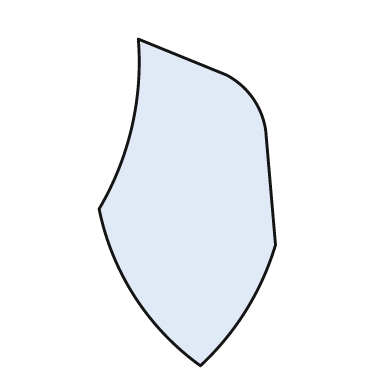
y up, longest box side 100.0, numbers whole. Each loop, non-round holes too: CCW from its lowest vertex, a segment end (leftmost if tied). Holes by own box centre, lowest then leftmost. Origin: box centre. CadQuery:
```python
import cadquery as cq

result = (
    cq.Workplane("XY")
    .moveTo(4.0, -50.0)
    .threePointArc((18.0, -33.0), (27.0, -13.0))
    .lineTo(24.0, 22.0)
    .threePointArc((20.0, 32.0), (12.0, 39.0))
    .lineTo(-15.0, 50.0)
    .threePointArc((-17.0, 23.0), (-27.0, -2.0))
    .threePointArc((-16.0, -29.0), (4.0, -50.0))
    .close()
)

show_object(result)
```